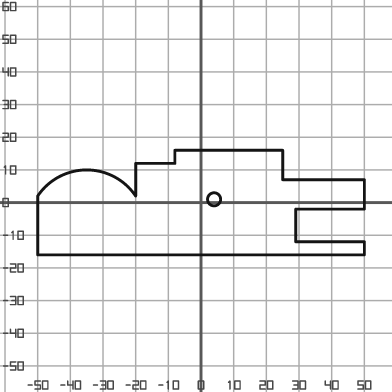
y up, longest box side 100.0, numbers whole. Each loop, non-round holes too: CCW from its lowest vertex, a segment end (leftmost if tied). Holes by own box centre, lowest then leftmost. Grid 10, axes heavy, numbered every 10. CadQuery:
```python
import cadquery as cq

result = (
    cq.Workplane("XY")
    .moveTo(-50.0, -16.0)
    .lineTo(50.0, -16.0)
    .lineTo(50.0, -12.0)
    .lineTo(29.0, -12.0)
    .lineTo(29.0, -2.0)
    .lineTo(50.0, -2.0)
    .lineTo(50.0, 7.0)
    .lineTo(25.0, 7.0)
    .lineTo(25.0, 16.0)
    .lineTo(-8.0, 16.0)
    .lineTo(-8.0, 12.0)
    .lineTo(-20.0, 12.0)
    .lineTo(-20.0, 2.0)
    .threePointArc((-35.0, 10.0), (-50.0, 2.0))
    .close()
    .moveTo(4.0, 1.0)
    .circle(2.0)
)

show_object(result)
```